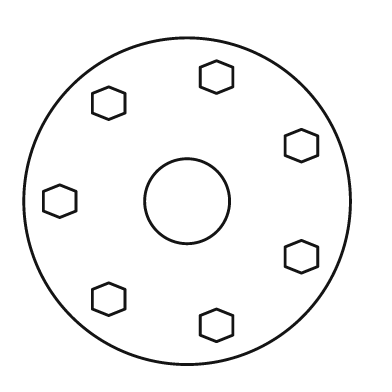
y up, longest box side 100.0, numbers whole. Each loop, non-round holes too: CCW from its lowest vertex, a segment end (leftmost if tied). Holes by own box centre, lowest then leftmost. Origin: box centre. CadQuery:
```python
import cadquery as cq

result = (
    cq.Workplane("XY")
    .moveTo(0.0, 0.0)
    .circle(50.0)
    .moveTo(9.0, -43.0)
    .lineTo(14.0, -41.0)
    .lineTo(14.0, -35.0)
    .lineTo(9.0, -33.0)
    .lineTo(4.0, -35.0)
    .lineTo(4.0, -41.0)
    .close()
    .moveTo(-24.0, -35.0)
    .lineTo(-19.0, -33.0)
    .lineTo(-19.0, -27.0)
    .lineTo(-24.0, -25.0)
    .lineTo(-29.0, -27.0)
    .lineTo(-29.0, -33.0)
    .close()
    .moveTo(35.0, -22.0)
    .lineTo(40.0, -20.0)
    .lineTo(40.0, -14.0)
    .lineTo(35.0, -12.0)
    .lineTo(30.0, -14.0)
    .lineTo(30.0, -20.0)
    .close()
    .moveTo(-39.0, -5.0)
    .lineTo(-34.0, -3.0)
    .lineTo(-34.0, 3.0)
    .lineTo(-39.0, 5.0)
    .lineTo(-44.0, 3.0)
    .lineTo(-44.0, -3.0)
    .close()
    .moveTo(0.0, 0.0)
    .circle(13.0)
    .moveTo(35.0, 12.0)
    .lineTo(40.0, 14.0)
    .lineTo(40.0, 20.0)
    .lineTo(35.0, 22.0)
    .lineTo(30.0, 20.0)
    .lineTo(30.0, 14.0)
    .close()
    .moveTo(-24.0, 25.0)
    .lineTo(-19.0, 27.0)
    .lineTo(-19.0, 33.0)
    .lineTo(-24.0, 35.0)
    .lineTo(-29.0, 33.0)
    .lineTo(-29.0, 27.0)
    .close()
    .moveTo(9.0, 33.0)
    .lineTo(14.0, 35.0)
    .lineTo(14.0, 41.0)
    .lineTo(9.0, 43.0)
    .lineTo(4.0, 41.0)
    .lineTo(4.0, 35.0)
    .close()
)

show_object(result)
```